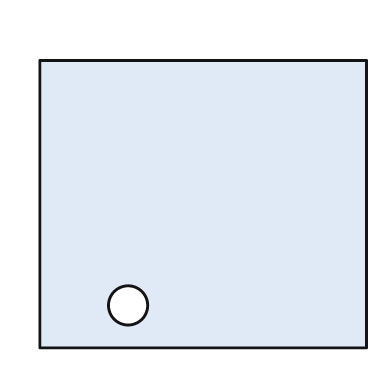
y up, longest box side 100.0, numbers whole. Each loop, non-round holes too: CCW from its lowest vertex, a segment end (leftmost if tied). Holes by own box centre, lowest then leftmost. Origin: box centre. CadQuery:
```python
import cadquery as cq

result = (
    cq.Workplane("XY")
    .moveTo(-50.0, -44.0)
    .lineTo(50.0, -44.0)
    .lineTo(50.0, 44.0)
    .lineTo(-50.0, 44.0)
    .close()
    .moveTo(-23.0, -31.0)
    .circle(6.0)
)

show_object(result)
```